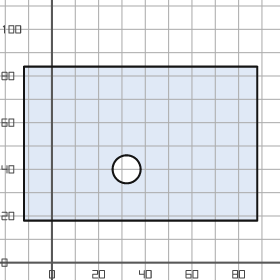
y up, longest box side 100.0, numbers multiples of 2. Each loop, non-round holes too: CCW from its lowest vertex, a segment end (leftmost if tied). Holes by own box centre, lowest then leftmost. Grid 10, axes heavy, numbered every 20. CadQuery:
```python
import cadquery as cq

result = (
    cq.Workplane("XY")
    .moveTo(-12.0, 18.0)
    .lineTo(88.0, 18.0)
    .lineTo(88.0, 84.0)
    .lineTo(-12.0, 84.0)
    .close()
    .moveTo(32.0, 40.0)
    .circle(6.0)
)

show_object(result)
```